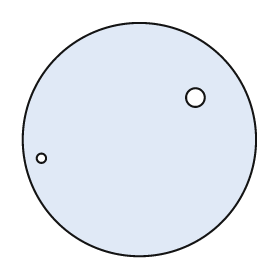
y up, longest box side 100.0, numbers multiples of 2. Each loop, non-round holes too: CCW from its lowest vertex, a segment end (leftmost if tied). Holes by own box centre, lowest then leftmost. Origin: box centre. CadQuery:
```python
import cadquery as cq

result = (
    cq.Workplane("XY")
    .moveTo(0.0, 0.0)
    .circle(50.0)
    .moveTo(-42.0, -8.0)
    .circle(2.0)
    .moveTo(24.0, 18.0)
    .circle(4.0)
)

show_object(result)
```